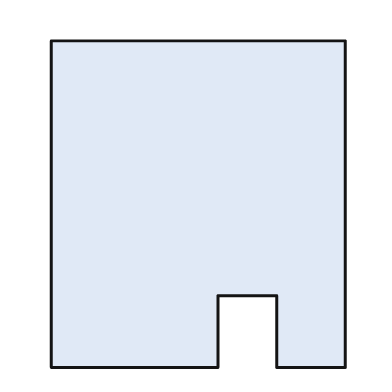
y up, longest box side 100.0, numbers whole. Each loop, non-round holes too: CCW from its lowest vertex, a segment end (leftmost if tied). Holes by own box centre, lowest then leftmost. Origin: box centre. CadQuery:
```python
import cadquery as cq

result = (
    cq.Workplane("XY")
    .moveTo(-45.0, -50.0)
    .lineTo(6.0, -50.0)
    .lineTo(6.0, -28.0)
    .lineTo(24.0, -28.0)
    .lineTo(24.0, -50.0)
    .lineTo(45.0, -50.0)
    .lineTo(45.0, 50.0)
    .lineTo(-45.0, 50.0)
    .close()
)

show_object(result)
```